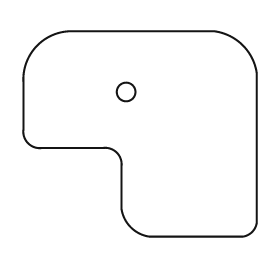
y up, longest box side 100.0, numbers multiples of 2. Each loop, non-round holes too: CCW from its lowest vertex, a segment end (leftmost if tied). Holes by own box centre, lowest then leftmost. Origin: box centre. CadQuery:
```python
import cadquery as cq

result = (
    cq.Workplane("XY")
    .moveTo(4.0, -44.0)
    .lineTo(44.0, -44.0)
    .threePointArc((48.0, -42.0), (50.0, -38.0))
    .lineTo(50.0, 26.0)
    .threePointArc((44.0, 38.0), (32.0, 44.0))
    .lineTo(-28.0, 44.0)
    .threePointArc((-44.0, 38.0), (-50.0, 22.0))
    .lineTo(-50.0, 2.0)
    .threePointArc((-48.0, -4.0), (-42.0, -6.0))
    .lineTo(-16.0, -6.0)
    .threePointArc((-10.0, -8.0), (-8.0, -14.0))
    .lineTo(-8.0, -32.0)
    .threePointArc((-4.0, -40.0), (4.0, -44.0))
    .close()
    .moveTo(-6.0, 18.0)
    .circle(4.0)
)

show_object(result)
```